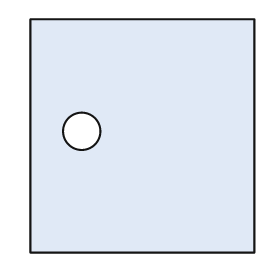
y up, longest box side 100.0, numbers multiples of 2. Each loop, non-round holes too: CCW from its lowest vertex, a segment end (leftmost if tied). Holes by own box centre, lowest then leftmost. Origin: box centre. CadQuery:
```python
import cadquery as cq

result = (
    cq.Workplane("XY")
    .moveTo(-48.0, -50.0)
    .lineTo(48.0, -50.0)
    .lineTo(48.0, 50.0)
    .lineTo(-48.0, 50.0)
    .close()
    .moveTo(-26.0, 2.0)
    .circle(8.0)
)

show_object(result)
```